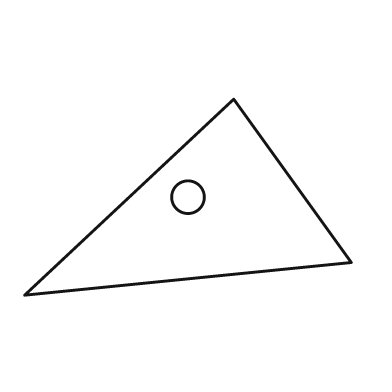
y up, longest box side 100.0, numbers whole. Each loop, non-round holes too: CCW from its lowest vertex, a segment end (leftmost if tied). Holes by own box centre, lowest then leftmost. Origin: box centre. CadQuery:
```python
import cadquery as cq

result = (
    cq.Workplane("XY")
    .moveTo(-50.0, -30.0)
    .lineTo(50.0, -20.0)
    .lineTo(14.0, 30.0)
    .close()
    .moveTo(0.0, 0.0)
    .circle(5.0)
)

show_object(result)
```